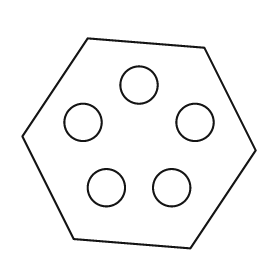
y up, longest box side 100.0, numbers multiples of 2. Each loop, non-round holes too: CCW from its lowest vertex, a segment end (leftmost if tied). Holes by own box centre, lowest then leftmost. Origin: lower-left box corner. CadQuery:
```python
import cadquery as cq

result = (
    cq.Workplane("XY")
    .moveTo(72.0, 0.0)
    .lineTo(100.0, 42.0)
    .lineTo(78.0, 86.0)
    .lineTo(28.0, 90.0)
    .lineTo(0.0, 48.0)
    .lineTo(22.0, 4.0)
    .close()
    .moveTo(36.0, 26.0)
    .circle(8.0)
    .moveTo(64.0, 26.0)
    .circle(8.0)
    .moveTo(26.0, 54.0)
    .circle(8.0)
    .moveTo(74.0, 54.0)
    .circle(8.0)
    .moveTo(50.0, 70.0)
    .circle(8.0)
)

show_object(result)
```